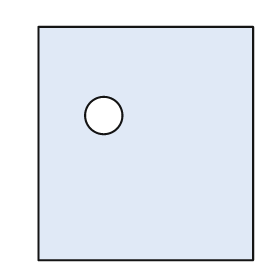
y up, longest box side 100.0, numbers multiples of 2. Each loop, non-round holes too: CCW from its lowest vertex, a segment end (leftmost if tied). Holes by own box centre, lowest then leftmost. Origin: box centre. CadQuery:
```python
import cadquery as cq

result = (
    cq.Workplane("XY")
    .moveTo(-46.0, -50.0)
    .lineTo(46.0, -50.0)
    .lineTo(46.0, 50.0)
    .lineTo(-46.0, 50.0)
    .close()
    .moveTo(-18.0, 12.0)
    .circle(8.0)
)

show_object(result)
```